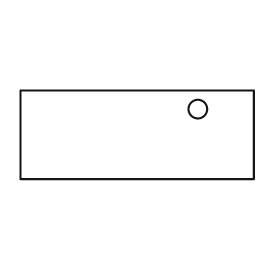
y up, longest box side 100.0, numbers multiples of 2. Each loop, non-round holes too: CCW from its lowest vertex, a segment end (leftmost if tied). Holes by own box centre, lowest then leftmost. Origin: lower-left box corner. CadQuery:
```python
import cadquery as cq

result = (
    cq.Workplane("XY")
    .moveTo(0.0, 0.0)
    .lineTo(100.0, 0.0)
    .lineTo(100.0, 38.0)
    .lineTo(0.0, 38.0)
    .close()
    .moveTo(76.0, 30.0)
    .circle(4.0)
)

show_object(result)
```